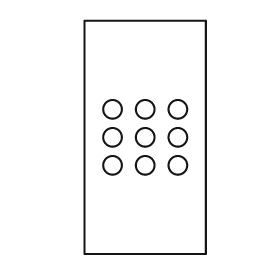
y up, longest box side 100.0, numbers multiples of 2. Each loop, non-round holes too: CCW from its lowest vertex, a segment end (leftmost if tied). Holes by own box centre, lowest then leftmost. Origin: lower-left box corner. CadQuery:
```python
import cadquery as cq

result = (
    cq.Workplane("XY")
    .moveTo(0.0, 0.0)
    .lineTo(52.0, 0.0)
    .lineTo(52.0, 100.0)
    .lineTo(0.0, 100.0)
    .close()
    .moveTo(12.0, 38.0)
    .circle(4.0)
    .moveTo(26.0, 38.0)
    .circle(4.0)
    .moveTo(40.0, 38.0)
    .circle(4.0)
    .moveTo(12.0, 50.0)
    .circle(4.0)
    .moveTo(26.0, 50.0)
    .circle(4.0)
    .moveTo(40.0, 50.0)
    .circle(4.0)
    .moveTo(12.0, 62.0)
    .circle(4.0)
    .moveTo(26.0, 62.0)
    .circle(4.0)
    .moveTo(40.0, 62.0)
    .circle(4.0)
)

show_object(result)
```